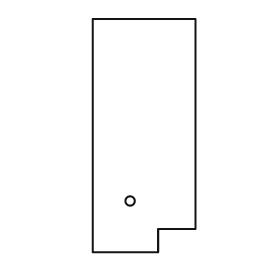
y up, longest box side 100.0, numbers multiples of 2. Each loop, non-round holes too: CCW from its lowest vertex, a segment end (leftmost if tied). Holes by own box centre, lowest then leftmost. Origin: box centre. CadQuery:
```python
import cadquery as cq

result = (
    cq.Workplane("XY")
    .moveTo(-22.0, -50.0)
    .lineTo(6.0, -50.0)
    .lineTo(6.0, -40.0)
    .lineTo(22.0, -40.0)
    .lineTo(22.0, 50.0)
    .lineTo(-22.0, 50.0)
    .close()
    .moveTo(-6.0, -28.0)
    .circle(2.0)
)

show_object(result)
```